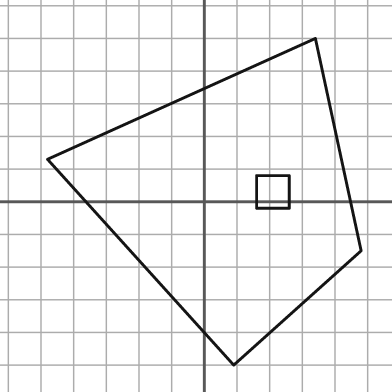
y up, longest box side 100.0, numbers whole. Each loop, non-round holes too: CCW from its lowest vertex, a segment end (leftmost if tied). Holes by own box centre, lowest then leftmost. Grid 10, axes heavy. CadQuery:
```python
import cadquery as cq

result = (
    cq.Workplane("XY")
    .moveTo(9.0, -50.0)
    .lineTo(48.0, -15.0)
    .lineTo(34.0, 50.0)
    .lineTo(-48.0, 13.0)
    .close()
    .moveTo(16.0, -2.0)
    .lineTo(26.0, -2.0)
    .lineTo(26.0, 8.0)
    .lineTo(16.0, 8.0)
    .close()
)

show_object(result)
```